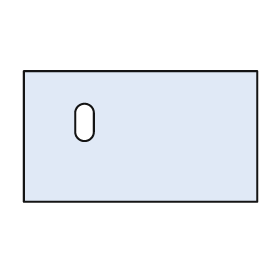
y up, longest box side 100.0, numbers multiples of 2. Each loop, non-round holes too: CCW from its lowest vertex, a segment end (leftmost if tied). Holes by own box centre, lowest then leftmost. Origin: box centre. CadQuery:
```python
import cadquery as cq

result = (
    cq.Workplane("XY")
    .moveTo(-50.0, -28.0)
    .lineTo(50.0, -28.0)
    .lineTo(50.0, 28.0)
    .lineTo(-50.0, 28.0)
    .close()
    .moveTo(-28.0, 2.0)
    .threePointArc((-24.0, -2.0), (-20.0, 2.0))
    .lineTo(-20.0, 10.0)
    .threePointArc((-24.0, 14.0), (-28.0, 10.0))
    .close()
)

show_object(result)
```